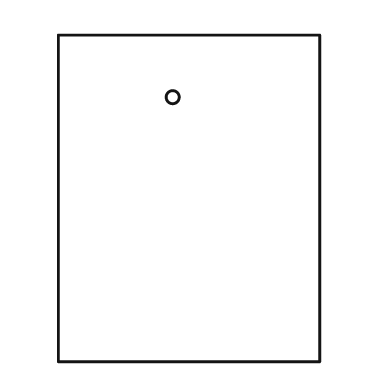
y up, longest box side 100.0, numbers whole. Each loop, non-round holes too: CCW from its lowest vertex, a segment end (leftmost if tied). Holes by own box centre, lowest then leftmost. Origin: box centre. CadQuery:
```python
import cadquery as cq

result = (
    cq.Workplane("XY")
    .moveTo(-40.0, -50.0)
    .lineTo(40.0, -50.0)
    .lineTo(40.0, 50.0)
    .lineTo(-40.0, 50.0)
    .close()
    .moveTo(-5.0, 31.0)
    .circle(2.0)
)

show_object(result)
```